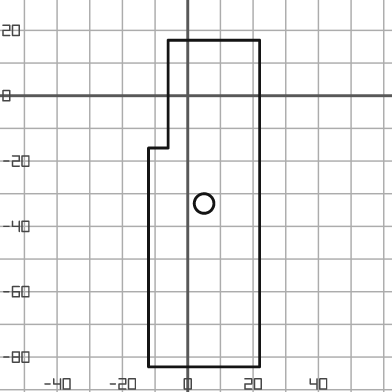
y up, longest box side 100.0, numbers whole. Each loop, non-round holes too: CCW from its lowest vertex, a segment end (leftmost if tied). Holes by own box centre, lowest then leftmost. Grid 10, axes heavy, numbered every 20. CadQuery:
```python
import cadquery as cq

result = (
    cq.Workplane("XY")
    .moveTo(-12.0, -83.0)
    .lineTo(22.0, -83.0)
    .lineTo(22.0, 17.0)
    .lineTo(-6.0, 17.0)
    .lineTo(-6.0, -16.0)
    .lineTo(-12.0, -16.0)
    .close()
    .moveTo(5.0, -33.0)
    .circle(3.0)
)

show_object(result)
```